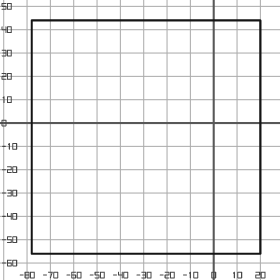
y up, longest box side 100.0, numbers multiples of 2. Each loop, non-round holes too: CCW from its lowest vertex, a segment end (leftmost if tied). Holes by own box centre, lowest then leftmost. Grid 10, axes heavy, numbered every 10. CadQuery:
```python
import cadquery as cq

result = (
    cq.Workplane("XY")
    .moveTo(-78.0, -56.0)
    .lineTo(20.0, -56.0)
    .lineTo(20.0, 44.0)
    .lineTo(-78.0, 44.0)
    .close()
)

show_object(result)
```